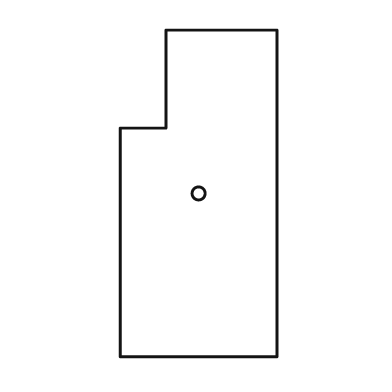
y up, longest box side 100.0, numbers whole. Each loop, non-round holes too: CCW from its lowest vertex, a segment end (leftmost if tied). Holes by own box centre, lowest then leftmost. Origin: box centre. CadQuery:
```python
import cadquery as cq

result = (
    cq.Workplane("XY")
    .moveTo(-24.0, -50.0)
    .lineTo(24.0, -50.0)
    .lineTo(24.0, 50.0)
    .lineTo(-10.0, 50.0)
    .lineTo(-10.0, 20.0)
    .lineTo(-24.0, 20.0)
    .close()
    .moveTo(0.0, 0.0)
    .circle(2.0)
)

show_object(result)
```